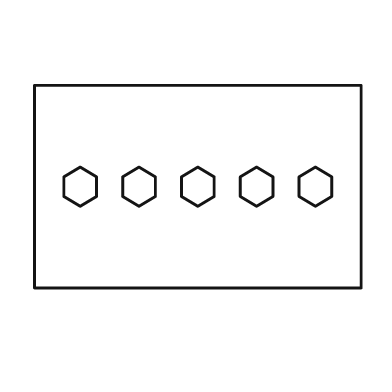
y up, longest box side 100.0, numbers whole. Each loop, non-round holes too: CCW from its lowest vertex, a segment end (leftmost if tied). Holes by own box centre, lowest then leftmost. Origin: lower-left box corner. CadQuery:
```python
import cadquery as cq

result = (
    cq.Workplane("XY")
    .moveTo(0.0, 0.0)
    .lineTo(100.0, 0.0)
    .lineTo(100.0, 62.0)
    .lineTo(0.0, 62.0)
    .close()
    .moveTo(14.0, 25.0)
    .lineTo(19.0, 28.0)
    .lineTo(19.0, 34.0)
    .lineTo(14.0, 37.0)
    .lineTo(9.0, 34.0)
    .lineTo(9.0, 28.0)
    .close()
    .moveTo(32.0, 25.0)
    .lineTo(37.0, 28.0)
    .lineTo(37.0, 34.0)
    .lineTo(32.0, 37.0)
    .lineTo(27.0, 34.0)
    .lineTo(27.0, 28.0)
    .close()
    .moveTo(50.0, 25.0)
    .lineTo(55.0, 28.0)
    .lineTo(55.0, 34.0)
    .lineTo(50.0, 37.0)
    .lineTo(45.0, 34.0)
    .lineTo(45.0, 28.0)
    .close()
    .moveTo(68.0, 25.0)
    .lineTo(73.0, 28.0)
    .lineTo(73.0, 34.0)
    .lineTo(68.0, 37.0)
    .lineTo(63.0, 34.0)
    .lineTo(63.0, 28.0)
    .close()
    .moveTo(86.0, 25.0)
    .lineTo(91.0, 28.0)
    .lineTo(91.0, 34.0)
    .lineTo(86.0, 37.0)
    .lineTo(81.0, 34.0)
    .lineTo(81.0, 28.0)
    .close()
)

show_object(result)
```